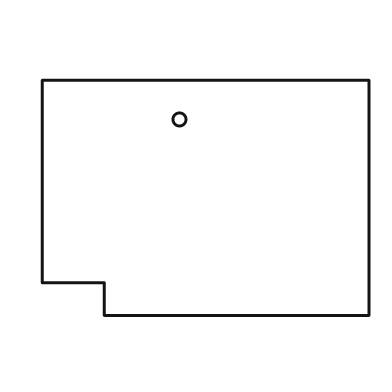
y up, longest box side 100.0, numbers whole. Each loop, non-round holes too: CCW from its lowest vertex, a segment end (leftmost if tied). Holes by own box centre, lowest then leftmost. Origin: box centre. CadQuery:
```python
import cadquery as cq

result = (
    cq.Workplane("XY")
    .moveTo(-31.0, -36.0)
    .lineTo(50.0, -36.0)
    .lineTo(50.0, 36.0)
    .lineTo(-50.0, 36.0)
    .lineTo(-50.0, -26.0)
    .lineTo(-31.0, -26.0)
    .close()
    .moveTo(-8.0, 24.0)
    .circle(2.0)
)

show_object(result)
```